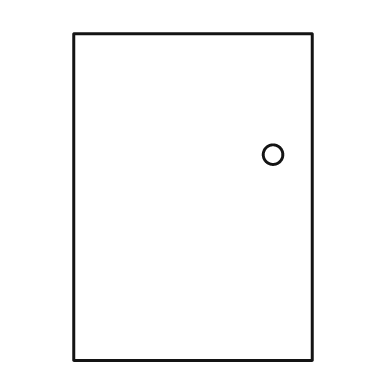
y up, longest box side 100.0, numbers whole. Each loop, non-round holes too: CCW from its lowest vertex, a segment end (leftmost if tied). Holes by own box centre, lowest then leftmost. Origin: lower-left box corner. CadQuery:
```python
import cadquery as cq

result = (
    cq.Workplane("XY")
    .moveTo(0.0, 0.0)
    .lineTo(73.0, 0.0)
    .lineTo(73.0, 100.0)
    .lineTo(0.0, 100.0)
    .close()
    .moveTo(61.0, 63.0)
    .circle(3.0)
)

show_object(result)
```